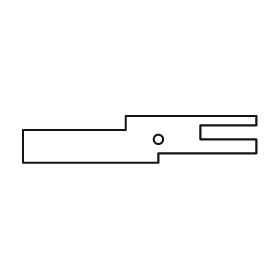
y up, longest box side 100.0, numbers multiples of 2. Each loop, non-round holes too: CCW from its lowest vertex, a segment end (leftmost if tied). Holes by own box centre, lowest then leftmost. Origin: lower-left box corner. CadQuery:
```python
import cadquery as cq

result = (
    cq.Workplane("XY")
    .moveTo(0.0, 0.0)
    .lineTo(58.0, 0.0)
    .lineTo(58.0, 4.0)
    .lineTo(100.0, 4.0)
    .lineTo(100.0, 10.0)
    .lineTo(76.0, 10.0)
    .lineTo(76.0, 16.0)
    .lineTo(100.0, 16.0)
    .lineTo(100.0, 20.0)
    .lineTo(44.0, 20.0)
    .lineTo(44.0, 14.0)
    .lineTo(0.0, 14.0)
    .close()
    .moveTo(58.0, 10.0)
    .circle(2.0)
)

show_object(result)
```